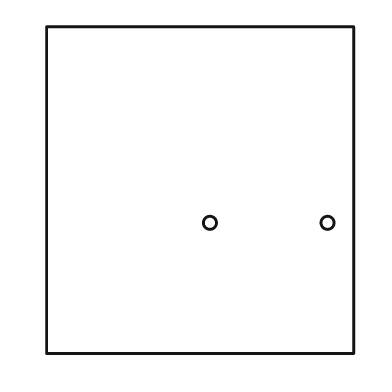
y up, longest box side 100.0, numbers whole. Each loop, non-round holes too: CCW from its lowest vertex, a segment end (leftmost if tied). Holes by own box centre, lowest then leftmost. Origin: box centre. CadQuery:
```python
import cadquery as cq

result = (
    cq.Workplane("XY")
    .moveTo(-47.0, -50.0)
    .lineTo(47.0, -50.0)
    .lineTo(47.0, 50.0)
    .lineTo(-47.0, 50.0)
    .close()
    .moveTo(3.0, -10.0)
    .circle(2.0)
    .moveTo(39.0, -10.0)
    .circle(2.0)
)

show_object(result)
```